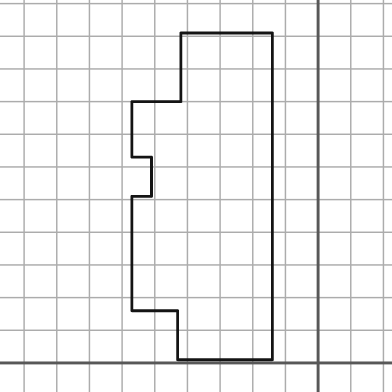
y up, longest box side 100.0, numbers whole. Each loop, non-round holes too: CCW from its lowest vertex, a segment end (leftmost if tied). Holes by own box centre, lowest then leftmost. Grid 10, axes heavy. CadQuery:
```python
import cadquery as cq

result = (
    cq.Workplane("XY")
    .moveTo(-43.0, 1.0)
    .lineTo(-14.0, 1.0)
    .lineTo(-14.0, 101.0)
    .lineTo(-42.0, 101.0)
    .lineTo(-42.0, 80.0)
    .lineTo(-57.0, 80.0)
    .lineTo(-57.0, 63.0)
    .lineTo(-51.0, 63.0)
    .lineTo(-51.0, 51.0)
    .lineTo(-57.0, 51.0)
    .lineTo(-57.0, 16.0)
    .lineTo(-43.0, 16.0)
    .close()
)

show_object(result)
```